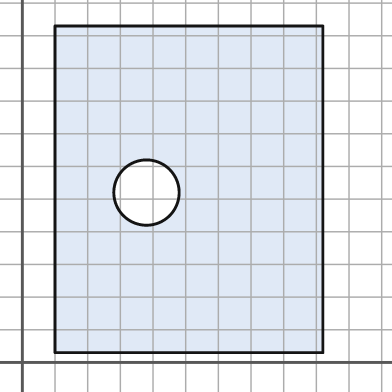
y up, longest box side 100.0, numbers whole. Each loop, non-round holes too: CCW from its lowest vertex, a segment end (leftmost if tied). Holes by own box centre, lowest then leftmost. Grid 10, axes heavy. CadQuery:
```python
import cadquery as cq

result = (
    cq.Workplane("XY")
    .moveTo(10.0, 3.0)
    .lineTo(92.0, 3.0)
    .lineTo(92.0, 103.0)
    .lineTo(10.0, 103.0)
    .close()
    .moveTo(38.0, 52.0)
    .circle(10.0)
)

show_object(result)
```